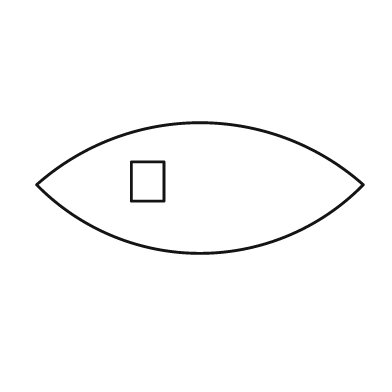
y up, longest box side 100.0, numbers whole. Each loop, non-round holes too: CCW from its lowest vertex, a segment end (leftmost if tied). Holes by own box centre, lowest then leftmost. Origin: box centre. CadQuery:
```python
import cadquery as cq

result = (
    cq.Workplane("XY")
    .moveTo(-50.0, 1.0)
    .threePointArc((0.0, -20.0), (50.0, 1.0))
    .threePointArc((0.0, 20.0), (-50.0, 1.0))
    .close()
    .moveTo(-21.0, -4.0)
    .lineTo(-11.0, -4.0)
    .lineTo(-11.0, 8.0)
    .lineTo(-21.0, 8.0)
    .close()
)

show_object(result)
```